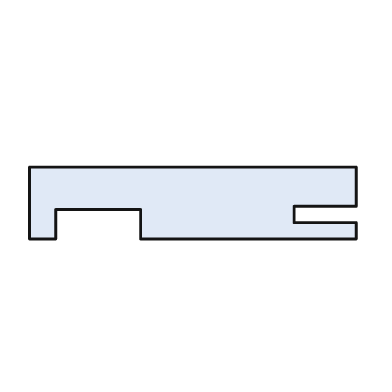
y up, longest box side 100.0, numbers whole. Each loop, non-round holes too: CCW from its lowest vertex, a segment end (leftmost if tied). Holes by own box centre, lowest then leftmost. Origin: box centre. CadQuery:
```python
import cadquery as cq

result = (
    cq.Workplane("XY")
    .moveTo(-50.0, -11.0)
    .lineTo(-42.0, -11.0)
    .lineTo(-42.0, -2.0)
    .lineTo(-16.0, -2.0)
    .lineTo(-16.0, -11.0)
    .lineTo(50.0, -11.0)
    .lineTo(50.0, -6.0)
    .lineTo(31.0, -6.0)
    .lineTo(31.0, -1.0)
    .lineTo(50.0, -1.0)
    .lineTo(50.0, 11.0)
    .lineTo(-50.0, 11.0)
    .close()
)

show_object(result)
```